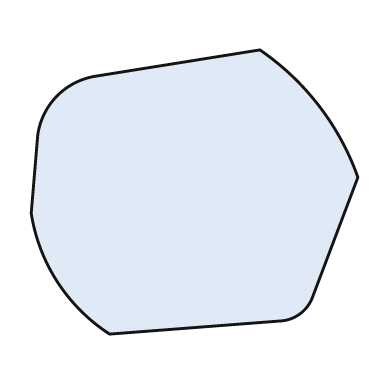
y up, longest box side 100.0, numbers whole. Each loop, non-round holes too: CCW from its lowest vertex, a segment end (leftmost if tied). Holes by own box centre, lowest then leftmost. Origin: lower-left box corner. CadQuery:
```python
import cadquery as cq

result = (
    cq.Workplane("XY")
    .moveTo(24.0, 0.0)
    .lineTo(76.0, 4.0)
    .threePointArc((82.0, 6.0), (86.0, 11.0))
    .lineTo(100.0, 48.0)
    .threePointArc((88.0, 70.0), (70.0, 87.0))
    .lineTo(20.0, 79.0)
    .threePointArc((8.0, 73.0), (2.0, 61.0))
    .lineTo(0.0, 37.0)
    .threePointArc((8.0, 16.0), (24.0, 0.0))
    .close()
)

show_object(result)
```